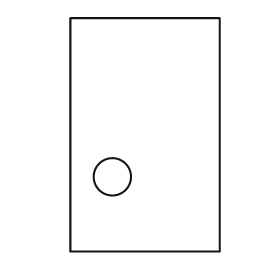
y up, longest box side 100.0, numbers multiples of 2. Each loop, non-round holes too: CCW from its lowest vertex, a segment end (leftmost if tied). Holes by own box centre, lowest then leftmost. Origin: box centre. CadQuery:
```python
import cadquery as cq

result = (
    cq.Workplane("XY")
    .moveTo(-32.0, -50.0)
    .lineTo(32.0, -50.0)
    .lineTo(32.0, 50.0)
    .lineTo(-32.0, 50.0)
    .close()
    .moveTo(-14.0, -18.0)
    .circle(8.0)
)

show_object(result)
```